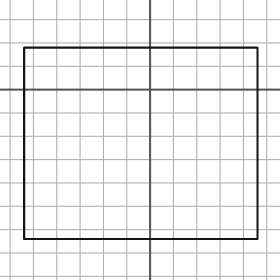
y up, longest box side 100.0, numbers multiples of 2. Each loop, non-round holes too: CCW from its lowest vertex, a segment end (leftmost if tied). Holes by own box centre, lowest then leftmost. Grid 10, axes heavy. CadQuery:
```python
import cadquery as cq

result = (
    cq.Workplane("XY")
    .moveTo(-54.0, -64.0)
    .lineTo(46.0, -64.0)
    .lineTo(46.0, 18.0)
    .lineTo(-54.0, 18.0)
    .close()
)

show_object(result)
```